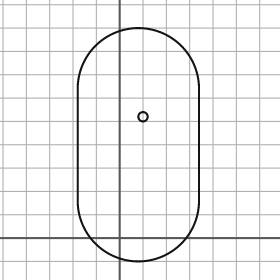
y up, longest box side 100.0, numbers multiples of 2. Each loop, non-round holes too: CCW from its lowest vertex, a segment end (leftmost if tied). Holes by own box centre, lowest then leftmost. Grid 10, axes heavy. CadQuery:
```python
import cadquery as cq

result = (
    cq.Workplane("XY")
    .moveTo(-18.0, 16.0)
    .threePointArc((8.0, -10.0), (34.0, 16.0))
    .lineTo(34.0, 64.0)
    .threePointArc((8.0, 90.0), (-18.0, 64.0))
    .close()
    .moveTo(10.0, 52.0)
    .circle(2.0)
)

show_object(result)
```